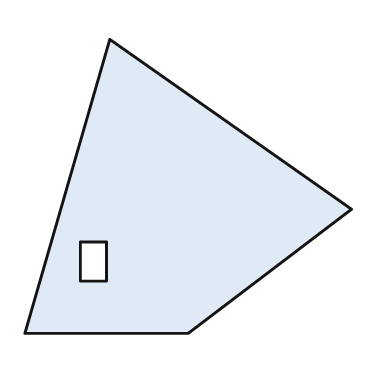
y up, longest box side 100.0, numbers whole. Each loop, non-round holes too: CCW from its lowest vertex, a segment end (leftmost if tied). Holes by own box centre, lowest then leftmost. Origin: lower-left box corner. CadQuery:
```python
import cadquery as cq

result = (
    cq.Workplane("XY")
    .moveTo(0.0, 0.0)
    .lineTo(50.0, 0.0)
    .lineTo(100.0, 38.0)
    .lineTo(26.0, 90.0)
    .close()
    .moveTo(17.0, 16.0)
    .lineTo(25.0, 16.0)
    .lineTo(25.0, 28.0)
    .lineTo(17.0, 28.0)
    .close()
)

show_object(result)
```